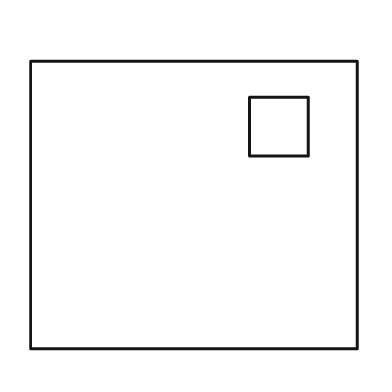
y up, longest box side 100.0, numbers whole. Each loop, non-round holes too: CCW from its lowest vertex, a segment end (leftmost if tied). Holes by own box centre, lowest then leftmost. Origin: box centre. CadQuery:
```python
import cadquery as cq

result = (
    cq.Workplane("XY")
    .moveTo(-50.0, -44.0)
    .lineTo(50.0, -44.0)
    .lineTo(50.0, 44.0)
    .lineTo(-50.0, 44.0)
    .close()
    .moveTo(17.0, 15.0)
    .lineTo(35.0, 15.0)
    .lineTo(35.0, 33.0)
    .lineTo(17.0, 33.0)
    .close()
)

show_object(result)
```